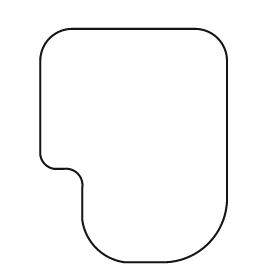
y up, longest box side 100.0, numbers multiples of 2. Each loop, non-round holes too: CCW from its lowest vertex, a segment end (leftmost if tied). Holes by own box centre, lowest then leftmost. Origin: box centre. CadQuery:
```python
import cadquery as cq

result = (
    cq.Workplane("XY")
    .moveTo(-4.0, -50.0)
    .lineTo(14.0, -50.0)
    .threePointArc((32.0, -42.0), (40.0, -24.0))
    .lineTo(40.0, 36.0)
    .threePointArc((36.0, 46.0), (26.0, 50.0))
    .lineTo(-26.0, 50.0)
    .threePointArc((-36.0, 46.0), (-40.0, 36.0))
    .lineTo(-40.0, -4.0)
    .threePointArc((-38.0, -8.0), (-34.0, -10.0))
    .lineTo(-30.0, -10.0)
    .threePointArc((-24.0, -12.0), (-22.0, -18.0))
    .lineTo(-22.0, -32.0)
    .threePointArc((-16.0, -44.0), (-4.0, -50.0))
    .close()
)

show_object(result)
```